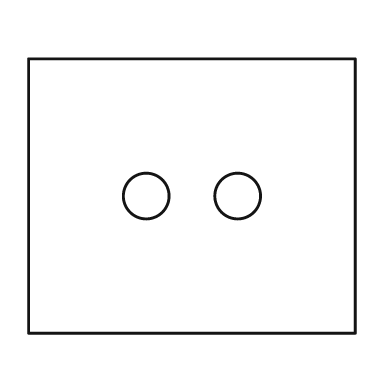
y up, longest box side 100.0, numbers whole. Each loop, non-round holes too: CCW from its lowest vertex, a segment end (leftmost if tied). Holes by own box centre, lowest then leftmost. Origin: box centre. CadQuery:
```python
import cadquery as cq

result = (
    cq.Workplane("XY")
    .moveTo(-50.0, -42.0)
    .lineTo(50.0, -42.0)
    .lineTo(50.0, 42.0)
    .lineTo(-50.0, 42.0)
    .close()
    .moveTo(-14.0, 0.0)
    .circle(7.0)
    .moveTo(14.0, 0.0)
    .circle(7.0)
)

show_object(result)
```